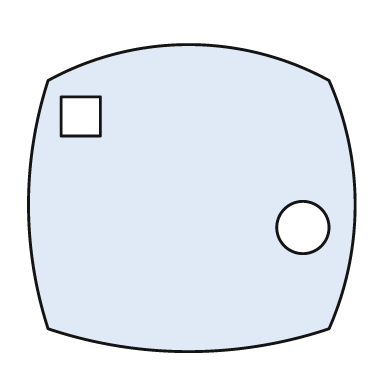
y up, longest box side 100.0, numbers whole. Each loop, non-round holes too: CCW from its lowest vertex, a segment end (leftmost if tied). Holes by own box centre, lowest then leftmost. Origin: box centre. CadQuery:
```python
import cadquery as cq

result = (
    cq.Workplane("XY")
    .moveTo(-44.0, -40.0)
    .threePointArc((-1.0, -47.0), (42.0, -40.0))
    .threePointArc((50.0, -2.0), (42.0, 36.0))
    .threePointArc((-1.0, 47.0), (-44.0, 36.0))
    .threePointArc((-50.0, -2.0), (-44.0, -40.0))
    .close()
    .moveTo(34.0, -9.0)
    .circle(8.0)
    .moveTo(-40.0, 19.0)
    .lineTo(-28.0, 19.0)
    .lineTo(-28.0, 31.0)
    .lineTo(-40.0, 31.0)
    .close()
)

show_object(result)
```